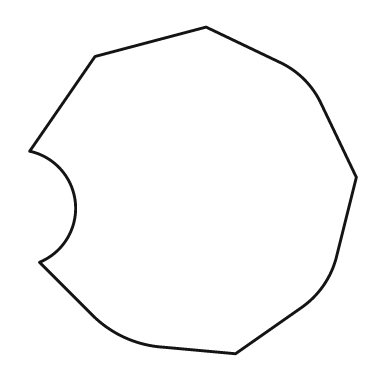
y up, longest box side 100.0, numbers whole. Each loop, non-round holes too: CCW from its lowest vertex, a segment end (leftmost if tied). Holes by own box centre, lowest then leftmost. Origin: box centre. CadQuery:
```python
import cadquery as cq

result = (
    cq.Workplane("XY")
    .moveTo(13.0, -50.0)
    .lineTo(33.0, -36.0)
    .threePointArc((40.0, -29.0), (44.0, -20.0))
    .lineTo(50.0, 4.0)
    .lineTo(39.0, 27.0)
    .threePointArc((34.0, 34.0), (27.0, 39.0))
    .lineTo(4.0, 50.0)
    .lineTo(-30.0, 41.0)
    .lineTo(-50.0, 12.0)
    .threePointArc((-36.0, -4.0), (-47.0, -22.0))
    .lineTo(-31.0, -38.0)
    .threePointArc((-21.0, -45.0), (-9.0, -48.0))
    .close()
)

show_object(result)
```